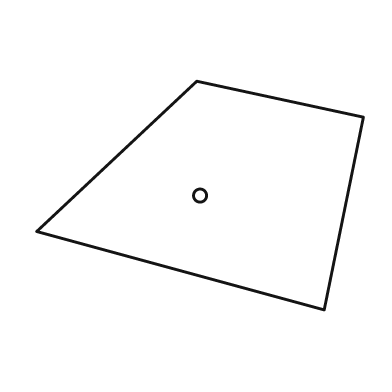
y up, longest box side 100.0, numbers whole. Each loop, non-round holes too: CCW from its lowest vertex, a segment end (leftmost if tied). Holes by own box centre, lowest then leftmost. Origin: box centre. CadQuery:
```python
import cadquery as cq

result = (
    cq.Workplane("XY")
    .moveTo(38.0, -35.0)
    .lineTo(50.0, 24.0)
    .lineTo(-1.0, 35.0)
    .lineTo(-50.0, -11.0)
    .close()
    .moveTo(0.0, 0.0)
    .circle(2.0)
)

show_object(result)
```